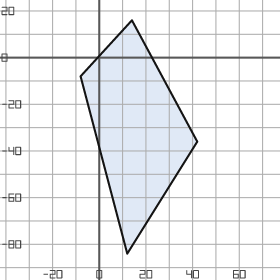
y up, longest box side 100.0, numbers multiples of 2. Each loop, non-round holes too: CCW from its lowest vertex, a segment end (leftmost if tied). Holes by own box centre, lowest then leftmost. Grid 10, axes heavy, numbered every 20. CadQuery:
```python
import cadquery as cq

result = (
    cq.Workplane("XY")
    .moveTo(12.0, -84.0)
    .lineTo(42.0, -36.0)
    .lineTo(14.0, 16.0)
    .lineTo(-8.0, -8.0)
    .close()
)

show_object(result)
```